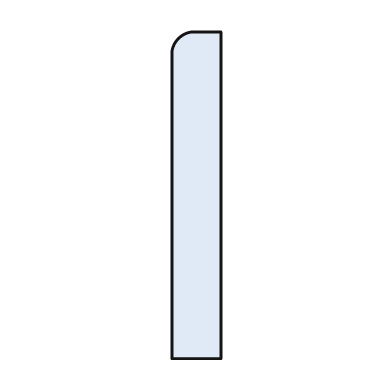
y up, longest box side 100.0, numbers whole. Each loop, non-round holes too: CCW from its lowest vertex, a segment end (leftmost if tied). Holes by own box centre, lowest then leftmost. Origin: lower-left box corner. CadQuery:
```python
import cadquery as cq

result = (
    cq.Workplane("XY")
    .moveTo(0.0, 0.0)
    .lineTo(15.0, 0.0)
    .lineTo(15.0, 100.0)
    .lineTo(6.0, 100.0)
    .threePointArc((2.0, 98.0), (0.0, 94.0))
    .close()
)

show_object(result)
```